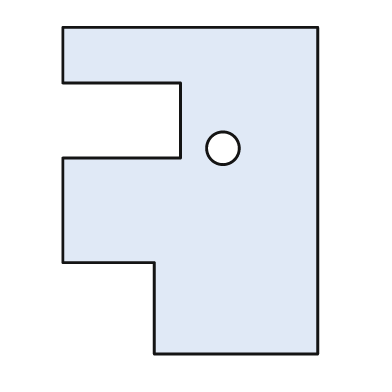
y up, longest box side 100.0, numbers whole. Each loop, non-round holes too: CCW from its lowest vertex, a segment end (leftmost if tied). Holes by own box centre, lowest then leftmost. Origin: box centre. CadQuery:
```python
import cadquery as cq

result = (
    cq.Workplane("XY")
    .moveTo(-11.0, -50.0)
    .lineTo(39.0, -50.0)
    .lineTo(39.0, 50.0)
    .lineTo(-39.0, 50.0)
    .lineTo(-39.0, 33.0)
    .lineTo(-3.0, 33.0)
    .lineTo(-3.0, 10.0)
    .lineTo(-39.0, 10.0)
    .lineTo(-39.0, -22.0)
    .lineTo(-11.0, -22.0)
    .close()
    .moveTo(10.0, 13.0)
    .circle(5.0)
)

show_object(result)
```